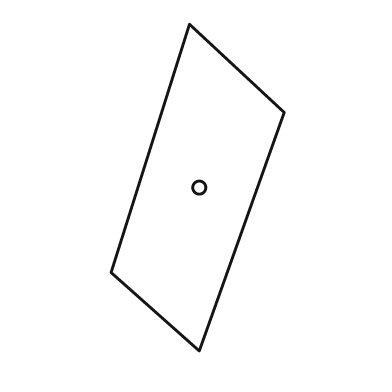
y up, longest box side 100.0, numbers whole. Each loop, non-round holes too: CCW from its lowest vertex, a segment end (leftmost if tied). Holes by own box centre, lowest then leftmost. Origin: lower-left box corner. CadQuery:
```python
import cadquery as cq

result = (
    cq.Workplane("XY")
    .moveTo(27.0, 0.0)
    .lineTo(53.0, 73.0)
    .lineTo(24.0, 100.0)
    .lineTo(0.0, 24.0)
    .close()
    .moveTo(27.0, 50.0)
    .circle(2.0)
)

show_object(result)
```